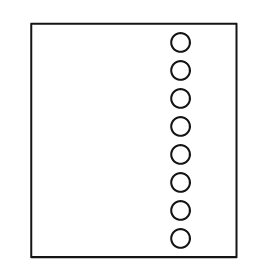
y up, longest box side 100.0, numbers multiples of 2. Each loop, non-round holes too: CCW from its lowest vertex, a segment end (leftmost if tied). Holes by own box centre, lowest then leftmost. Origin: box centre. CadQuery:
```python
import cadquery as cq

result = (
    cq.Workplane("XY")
    .moveTo(-44.0, -50.0)
    .lineTo(44.0, -50.0)
    .lineTo(44.0, 50.0)
    .lineTo(-44.0, 50.0)
    .close()
    .moveTo(20.0, -42.0)
    .circle(4.0)
    .moveTo(20.0, -30.0)
    .circle(4.0)
    .moveTo(20.0, -18.0)
    .circle(4.0)
    .moveTo(20.0, -6.0)
    .circle(4.0)
    .moveTo(20.0, 6.0)
    .circle(4.0)
    .moveTo(20.0, 18.0)
    .circle(4.0)
    .moveTo(20.0, 30.0)
    .circle(4.0)
    .moveTo(20.0, 42.0)
    .circle(4.0)
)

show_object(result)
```